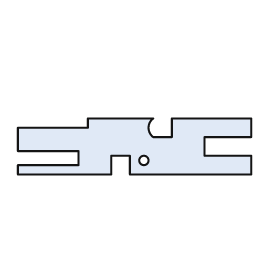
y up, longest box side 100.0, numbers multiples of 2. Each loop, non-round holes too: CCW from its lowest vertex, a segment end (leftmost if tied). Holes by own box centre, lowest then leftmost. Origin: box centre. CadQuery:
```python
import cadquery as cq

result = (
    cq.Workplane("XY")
    .moveTo(-50.0, -12.0)
    .lineTo(-10.0, -12.0)
    .lineTo(-10.0, -4.0)
    .lineTo(-2.0, -4.0)
    .lineTo(-2.0, -12.0)
    .lineTo(50.0, -12.0)
    .lineTo(50.0, -4.0)
    .lineTo(30.0, -4.0)
    .lineTo(30.0, 4.0)
    .lineTo(50.0, 4.0)
    .lineTo(50.0, 12.0)
    .lineTo(16.0, 12.0)
    .lineTo(16.0, 4.0)
    .lineTo(8.0, 4.0)
    .threePointArc((6.0, 8.0), (8.0, 12.0))
    .lineTo(-20.0, 12.0)
    .lineTo(-20.0, 8.0)
    .lineTo(-50.0, 8.0)
    .lineTo(-50.0, -2.0)
    .lineTo(-24.0, -2.0)
    .lineTo(-24.0, -8.0)
    .lineTo(-50.0, -8.0)
    .close()
    .moveTo(4.0, -6.0)
    .circle(2.0)
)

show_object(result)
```